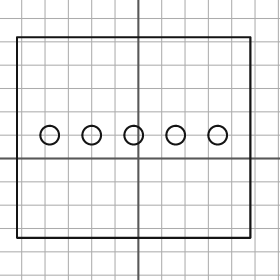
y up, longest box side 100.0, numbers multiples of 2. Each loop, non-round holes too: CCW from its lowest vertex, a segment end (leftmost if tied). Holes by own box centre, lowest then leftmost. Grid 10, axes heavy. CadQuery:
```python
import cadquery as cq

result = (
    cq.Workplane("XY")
    .moveTo(-52.0, -34.0)
    .lineTo(48.0, -34.0)
    .lineTo(48.0, 52.0)
    .lineTo(-52.0, 52.0)
    .close()
    .moveTo(-38.0, 10.0)
    .circle(4.0)
    .moveTo(-20.0, 10.0)
    .circle(4.0)
    .moveTo(-2.0, 10.0)
    .circle(4.0)
    .moveTo(16.0, 10.0)
    .circle(4.0)
    .moveTo(34.0, 10.0)
    .circle(4.0)
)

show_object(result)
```